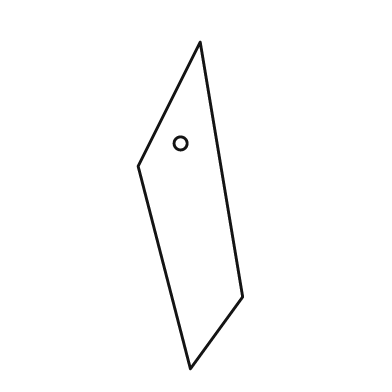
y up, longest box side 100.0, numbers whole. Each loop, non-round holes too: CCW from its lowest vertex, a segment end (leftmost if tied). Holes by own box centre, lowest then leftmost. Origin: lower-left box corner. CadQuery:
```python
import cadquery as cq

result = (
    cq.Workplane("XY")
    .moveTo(16.0, 0.0)
    .lineTo(32.0, 22.0)
    .lineTo(19.0, 100.0)
    .lineTo(0.0, 62.0)
    .close()
    .moveTo(13.0, 69.0)
    .circle(2.0)
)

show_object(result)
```